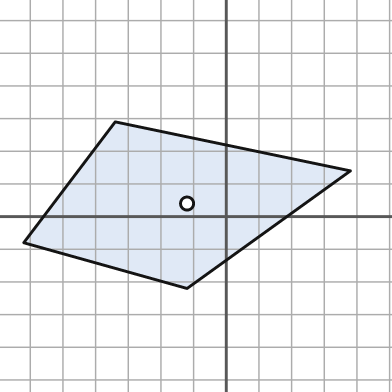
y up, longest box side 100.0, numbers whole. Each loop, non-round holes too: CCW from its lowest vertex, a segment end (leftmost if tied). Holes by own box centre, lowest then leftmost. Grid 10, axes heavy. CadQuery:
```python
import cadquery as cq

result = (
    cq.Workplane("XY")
    .moveTo(-12.0, -22.0)
    .lineTo(38.0, 14.0)
    .lineTo(-34.0, 29.0)
    .lineTo(-62.0, -8.0)
    .close()
    .moveTo(-12.0, 4.0)
    .circle(2.0)
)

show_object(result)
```